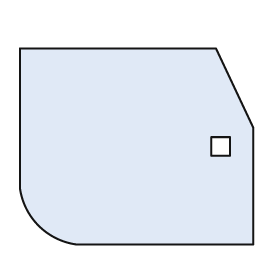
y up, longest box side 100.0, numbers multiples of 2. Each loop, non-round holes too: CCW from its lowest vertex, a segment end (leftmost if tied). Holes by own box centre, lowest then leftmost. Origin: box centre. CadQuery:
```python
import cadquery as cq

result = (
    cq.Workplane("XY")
    .moveTo(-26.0, -42.0)
    .lineTo(50.0, -42.0)
    .lineTo(50.0, 8.0)
    .lineTo(34.0, 42.0)
    .lineTo(-50.0, 42.0)
    .lineTo(-50.0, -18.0)
    .threePointArc((-42.0, -34.0), (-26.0, -42.0))
    .close()
    .moveTo(32.0, -4.0)
    .lineTo(40.0, -4.0)
    .lineTo(40.0, 4.0)
    .lineTo(32.0, 4.0)
    .close()
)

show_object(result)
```